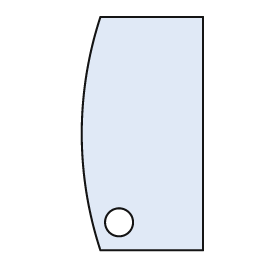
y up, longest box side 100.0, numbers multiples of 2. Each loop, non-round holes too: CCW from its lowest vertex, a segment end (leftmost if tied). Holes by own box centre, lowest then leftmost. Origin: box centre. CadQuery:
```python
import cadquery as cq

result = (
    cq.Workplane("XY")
    .moveTo(-18.0, -50.0)
    .lineTo(26.0, -50.0)
    .lineTo(26.0, 50.0)
    .lineTo(-18.0, 50.0)
    .threePointArc((-26.0, 0.0), (-18.0, -50.0))
    .close()
    .moveTo(-10.0, -38.0)
    .circle(6.0)
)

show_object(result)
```